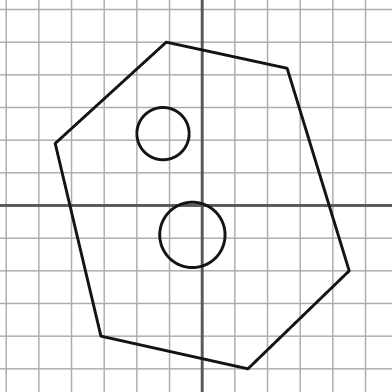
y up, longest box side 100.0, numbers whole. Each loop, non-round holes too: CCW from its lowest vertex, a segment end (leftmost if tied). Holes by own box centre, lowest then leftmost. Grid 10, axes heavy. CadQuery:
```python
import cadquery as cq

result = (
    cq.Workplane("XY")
    .moveTo(14.0, -50.0)
    .lineTo(45.0, -20.0)
    .lineTo(26.0, 42.0)
    .lineTo(-11.0, 50.0)
    .lineTo(-45.0, 19.0)
    .lineTo(-31.0, -40.0)
    .close()
    .moveTo(-3.0, -9.0)
    .circle(10.0)
    .moveTo(-12.0, 22.0)
    .circle(8.0)
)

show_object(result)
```